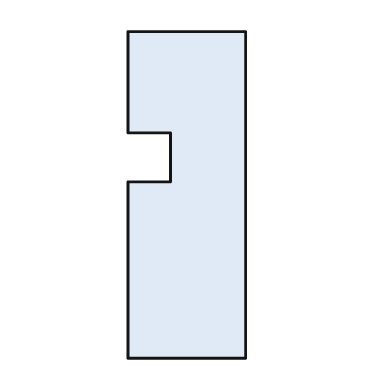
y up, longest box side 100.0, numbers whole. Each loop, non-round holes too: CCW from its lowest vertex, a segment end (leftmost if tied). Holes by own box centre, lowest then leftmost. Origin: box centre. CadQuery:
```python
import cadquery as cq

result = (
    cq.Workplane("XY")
    .moveTo(-18.0, -50.0)
    .lineTo(18.0, -50.0)
    .lineTo(18.0, 50.0)
    .lineTo(-18.0, 50.0)
    .lineTo(-18.0, 19.0)
    .lineTo(-5.0, 19.0)
    .lineTo(-5.0, 4.0)
    .lineTo(-18.0, 4.0)
    .close()
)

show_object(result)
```